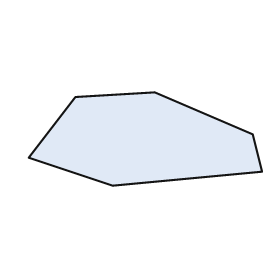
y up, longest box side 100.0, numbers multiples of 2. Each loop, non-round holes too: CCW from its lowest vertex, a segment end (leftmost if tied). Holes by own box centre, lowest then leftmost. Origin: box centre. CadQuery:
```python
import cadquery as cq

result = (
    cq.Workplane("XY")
    .moveTo(-14.0, -20.0)
    .lineTo(50.0, -14.0)
    .lineTo(46.0, 2.0)
    .lineTo(4.0, 20.0)
    .lineTo(-30.0, 18.0)
    .lineTo(-50.0, -8.0)
    .close()
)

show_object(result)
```